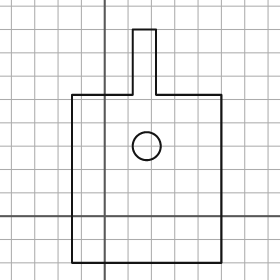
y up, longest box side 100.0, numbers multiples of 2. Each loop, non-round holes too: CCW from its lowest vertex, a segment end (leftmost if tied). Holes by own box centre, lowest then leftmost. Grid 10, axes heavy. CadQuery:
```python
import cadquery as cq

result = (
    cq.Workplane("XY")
    .moveTo(-14.0, -20.0)
    .lineTo(50.0, -20.0)
    .lineTo(50.0, 52.0)
    .lineTo(22.0, 52.0)
    .lineTo(22.0, 80.0)
    .lineTo(12.0, 80.0)
    .lineTo(12.0, 52.0)
    .lineTo(-14.0, 52.0)
    .close()
    .moveTo(18.0, 30.0)
    .circle(6.0)
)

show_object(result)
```